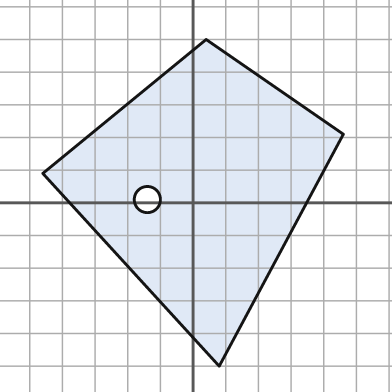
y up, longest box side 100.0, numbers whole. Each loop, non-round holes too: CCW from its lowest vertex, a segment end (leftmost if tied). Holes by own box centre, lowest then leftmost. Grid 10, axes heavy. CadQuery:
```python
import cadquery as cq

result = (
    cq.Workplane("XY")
    .moveTo(8.0, -50.0)
    .lineTo(46.0, 21.0)
    .lineTo(4.0, 50.0)
    .lineTo(-46.0, 9.0)
    .close()
    .moveTo(-14.0, 1.0)
    .circle(4.0)
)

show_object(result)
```